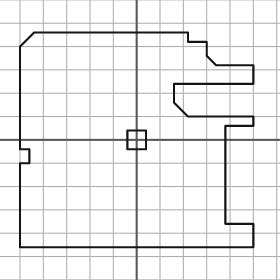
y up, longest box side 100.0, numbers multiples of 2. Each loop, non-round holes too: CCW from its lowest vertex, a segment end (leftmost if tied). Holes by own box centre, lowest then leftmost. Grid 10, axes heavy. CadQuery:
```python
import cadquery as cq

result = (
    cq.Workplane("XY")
    .moveTo(-50.0, -46.0)
    .lineTo(50.0, -46.0)
    .lineTo(50.0, -36.0)
    .lineTo(38.0, -36.0)
    .lineTo(38.0, 6.0)
    .lineTo(50.0, 6.0)
    .lineTo(50.0, 10.0)
    .lineTo(22.0, 10.0)
    .lineTo(16.0, 16.0)
    .lineTo(16.0, 24.0)
    .lineTo(50.0, 24.0)
    .lineTo(50.0, 32.0)
    .lineTo(34.0, 32.0)
    .lineTo(30.0, 36.0)
    .lineTo(30.0, 42.0)
    .lineTo(22.0, 42.0)
    .lineTo(22.0, 46.0)
    .lineTo(-44.0, 46.0)
    .lineTo(-50.0, 40.0)
    .lineTo(-50.0, -4.0)
    .lineTo(-46.0, -4.0)
    .lineTo(-46.0, -10.0)
    .lineTo(-50.0, -10.0)
    .close()
    .moveTo(-4.0, -4.0)
    .lineTo(4.0, -4.0)
    .lineTo(4.0, 4.0)
    .lineTo(-4.0, 4.0)
    .close()
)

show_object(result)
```